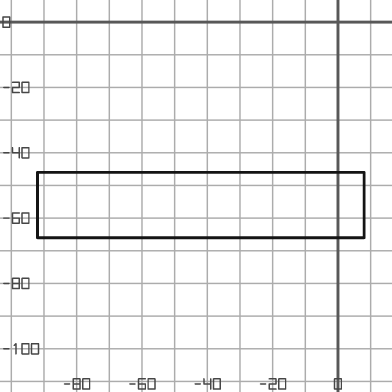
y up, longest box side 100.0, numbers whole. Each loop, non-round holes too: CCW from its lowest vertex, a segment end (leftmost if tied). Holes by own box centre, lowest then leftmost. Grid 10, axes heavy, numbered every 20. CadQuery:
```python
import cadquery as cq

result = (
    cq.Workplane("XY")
    .moveTo(-92.0, -66.0)
    .lineTo(8.0, -66.0)
    .lineTo(8.0, -46.0)
    .lineTo(-92.0, -46.0)
    .close()
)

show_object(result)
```